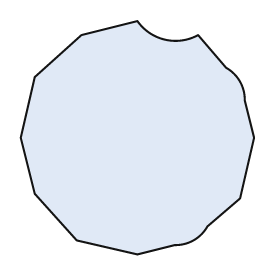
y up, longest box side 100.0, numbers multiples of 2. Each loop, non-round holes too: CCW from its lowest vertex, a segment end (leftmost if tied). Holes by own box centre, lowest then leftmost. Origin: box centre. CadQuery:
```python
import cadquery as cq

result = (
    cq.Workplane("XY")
    .moveTo(0.0, -50.0)
    .lineTo(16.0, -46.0)
    .threePointArc((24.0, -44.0), (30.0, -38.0))
    .lineTo(44.0, -26.0)
    .lineTo(50.0, 0.0)
    .lineTo(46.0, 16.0)
    .threePointArc((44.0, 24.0), (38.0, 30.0))
    .lineTo(26.0, 44.0)
    .threePointArc((12.0, 42.0), (0.0, 50.0))
    .lineTo(-24.0, 44.0)
    .lineTo(-44.0, 26.0)
    .lineTo(-50.0, 0.0)
    .lineTo(-44.0, -24.0)
    .lineTo(-26.0, -44.0)
    .close()
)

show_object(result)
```